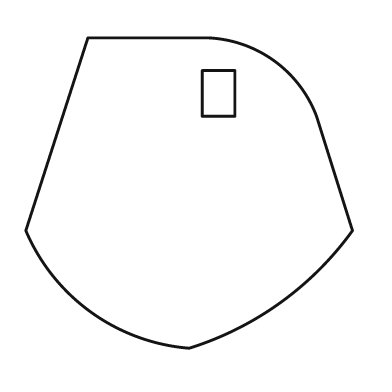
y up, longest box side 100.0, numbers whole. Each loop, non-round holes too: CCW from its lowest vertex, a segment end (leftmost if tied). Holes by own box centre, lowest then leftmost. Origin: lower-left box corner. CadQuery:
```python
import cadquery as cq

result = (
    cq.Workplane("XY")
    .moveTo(50.0, 0.0)
    .threePointArc((78.0, 14.0), (100.0, 36.0))
    .lineTo(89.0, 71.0)
    .threePointArc((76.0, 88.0), (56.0, 95.0))
    .lineTo(19.0, 95.0)
    .lineTo(0.0, 36.0)
    .threePointArc((20.0, 11.0), (50.0, 0.0))
    .close()
    .moveTo(54.0, 71.0)
    .lineTo(64.0, 71.0)
    .lineTo(64.0, 85.0)
    .lineTo(54.0, 85.0)
    .close()
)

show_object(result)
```